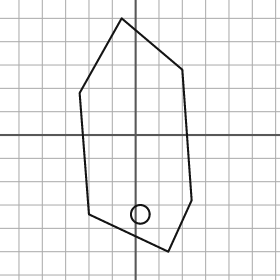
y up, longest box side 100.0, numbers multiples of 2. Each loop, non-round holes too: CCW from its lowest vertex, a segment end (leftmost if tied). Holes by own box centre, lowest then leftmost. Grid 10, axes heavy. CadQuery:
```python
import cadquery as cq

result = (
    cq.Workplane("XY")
    .moveTo(14.0, -50.0)
    .lineTo(24.0, -28.0)
    .lineTo(20.0, 28.0)
    .lineTo(-6.0, 50.0)
    .lineTo(-24.0, 18.0)
    .lineTo(-20.0, -34.0)
    .close()
    .moveTo(2.0, -34.0)
    .circle(4.0)
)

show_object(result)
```